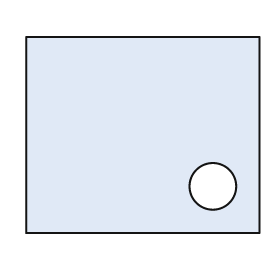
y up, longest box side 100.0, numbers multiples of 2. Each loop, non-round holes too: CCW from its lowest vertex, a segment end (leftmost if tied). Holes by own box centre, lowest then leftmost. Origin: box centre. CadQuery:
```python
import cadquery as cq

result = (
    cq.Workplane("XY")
    .moveTo(-50.0, -42.0)
    .lineTo(50.0, -42.0)
    .lineTo(50.0, 42.0)
    .lineTo(-50.0, 42.0)
    .close()
    .moveTo(30.0, -22.0)
    .circle(10.0)
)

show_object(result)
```